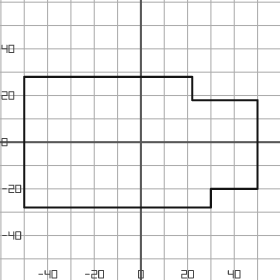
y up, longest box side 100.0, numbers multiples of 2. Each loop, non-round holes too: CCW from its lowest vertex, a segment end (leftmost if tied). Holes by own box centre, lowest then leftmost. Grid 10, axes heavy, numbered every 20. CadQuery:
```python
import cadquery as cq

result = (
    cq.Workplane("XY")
    .moveTo(-50.0, -28.0)
    .lineTo(30.0, -28.0)
    .lineTo(30.0, -20.0)
    .lineTo(50.0, -20.0)
    .lineTo(50.0, 18.0)
    .lineTo(22.0, 18.0)
    .lineTo(22.0, 28.0)
    .lineTo(-50.0, 28.0)
    .close()
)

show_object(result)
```